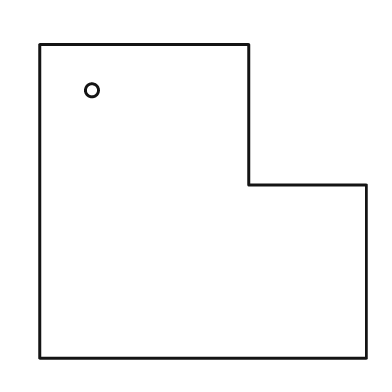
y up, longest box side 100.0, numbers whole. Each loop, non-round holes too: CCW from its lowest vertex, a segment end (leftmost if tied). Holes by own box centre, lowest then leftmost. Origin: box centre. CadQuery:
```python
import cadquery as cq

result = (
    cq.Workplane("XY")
    .moveTo(-50.0, -48.0)
    .lineTo(50.0, -48.0)
    .lineTo(50.0, 5.0)
    .lineTo(14.0, 5.0)
    .lineTo(14.0, 48.0)
    .lineTo(-50.0, 48.0)
    .close()
    .moveTo(-34.0, 34.0)
    .circle(2.0)
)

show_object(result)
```